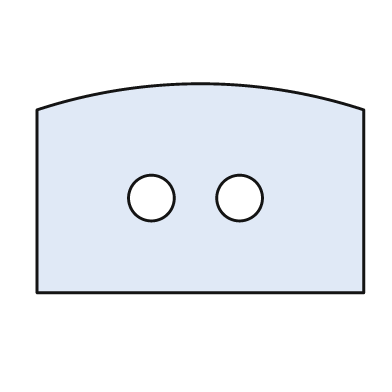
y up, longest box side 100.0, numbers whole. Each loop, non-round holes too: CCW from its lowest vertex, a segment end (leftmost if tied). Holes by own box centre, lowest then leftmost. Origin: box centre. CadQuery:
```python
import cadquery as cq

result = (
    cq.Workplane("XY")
    .moveTo(-50.0, -32.0)
    .lineTo(50.0, -32.0)
    .lineTo(50.0, 24.0)
    .threePointArc((0.0, 32.0), (-50.0, 24.0))
    .close()
    .moveTo(-15.0, -3.0)
    .circle(7.0)
    .moveTo(12.0, -3.0)
    .circle(7.0)
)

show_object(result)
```